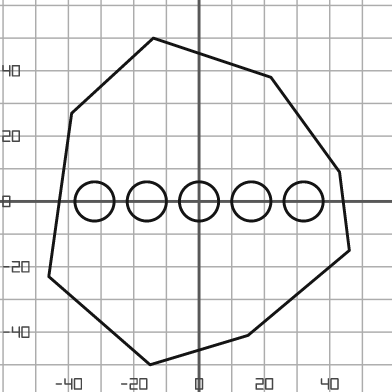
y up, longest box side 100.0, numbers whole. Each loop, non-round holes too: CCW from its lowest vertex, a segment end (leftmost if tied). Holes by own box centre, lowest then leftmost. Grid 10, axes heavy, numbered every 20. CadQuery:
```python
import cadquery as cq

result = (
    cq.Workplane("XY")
    .moveTo(-15.0, -50.0)
    .lineTo(15.0, -41.0)
    .lineTo(46.0, -15.0)
    .lineTo(43.0, 9.0)
    .lineTo(22.0, 38.0)
    .lineTo(-14.0, 50.0)
    .lineTo(-39.0, 27.0)
    .lineTo(-46.0, -23.0)
    .close()
    .moveTo(-32.0, 0.0)
    .circle(6.0)
    .moveTo(-16.0, 0.0)
    .circle(6.0)
    .moveTo(0.0, 0.0)
    .circle(6.0)
    .moveTo(16.0, 0.0)
    .circle(6.0)
    .moveTo(32.0, 0.0)
    .circle(6.0)
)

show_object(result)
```